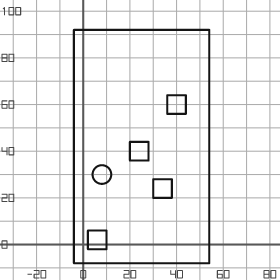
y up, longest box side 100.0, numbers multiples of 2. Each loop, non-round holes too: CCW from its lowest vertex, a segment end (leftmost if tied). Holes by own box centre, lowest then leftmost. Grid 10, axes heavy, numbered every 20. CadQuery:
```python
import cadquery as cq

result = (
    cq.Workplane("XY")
    .moveTo(-4.0, -8.0)
    .lineTo(54.0, -8.0)
    .lineTo(54.0, 92.0)
    .lineTo(-4.0, 92.0)
    .close()
    .moveTo(2.0, -2.0)
    .lineTo(10.0, -2.0)
    .lineTo(10.0, 6.0)
    .lineTo(2.0, 6.0)
    .close()
    .moveTo(30.0, 20.0)
    .lineTo(38.0, 20.0)
    .lineTo(38.0, 28.0)
    .lineTo(30.0, 28.0)
    .close()
    .moveTo(8.0, 30.0)
    .circle(4.0)
    .moveTo(20.0, 36.0)
    .lineTo(28.0, 36.0)
    .lineTo(28.0, 44.0)
    .lineTo(20.0, 44.0)
    .close()
    .moveTo(36.0, 56.0)
    .lineTo(44.0, 56.0)
    .lineTo(44.0, 64.0)
    .lineTo(36.0, 64.0)
    .close()
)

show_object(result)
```